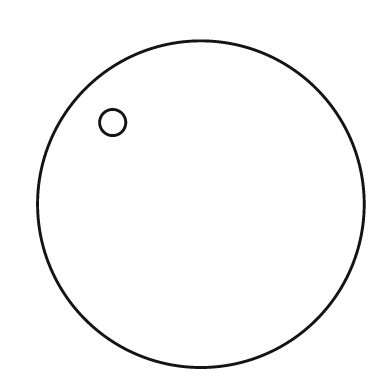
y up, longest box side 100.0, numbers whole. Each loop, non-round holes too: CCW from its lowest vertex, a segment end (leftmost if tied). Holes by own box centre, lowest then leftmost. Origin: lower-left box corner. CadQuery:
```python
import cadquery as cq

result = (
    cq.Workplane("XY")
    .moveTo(50.0, 50.0)
    .circle(50.0)
    .moveTo(23.0, 75.0)
    .circle(4.0)
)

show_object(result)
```